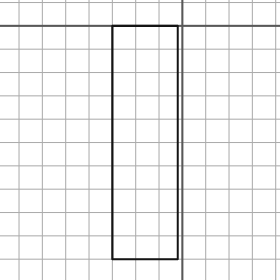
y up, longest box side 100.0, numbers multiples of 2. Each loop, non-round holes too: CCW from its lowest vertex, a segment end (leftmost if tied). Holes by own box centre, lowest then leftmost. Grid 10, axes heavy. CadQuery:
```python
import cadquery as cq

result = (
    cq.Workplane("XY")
    .moveTo(-30.0, -100.0)
    .lineTo(-2.0, -100.0)
    .lineTo(-2.0, 0.0)
    .lineTo(-30.0, 0.0)
    .close()
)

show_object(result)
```